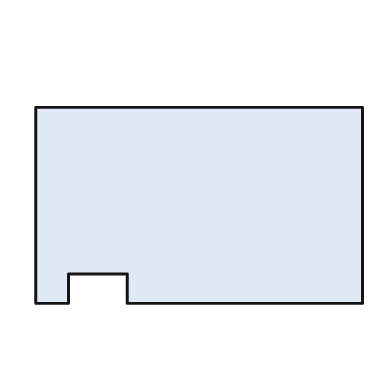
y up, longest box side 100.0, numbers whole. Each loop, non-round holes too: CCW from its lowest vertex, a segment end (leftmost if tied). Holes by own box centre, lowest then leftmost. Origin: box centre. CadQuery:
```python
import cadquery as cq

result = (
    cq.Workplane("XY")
    .moveTo(-50.0, -30.0)
    .lineTo(-40.0, -30.0)
    .lineTo(-40.0, -21.0)
    .lineTo(-22.0, -21.0)
    .lineTo(-22.0, -30.0)
    .lineTo(50.0, -30.0)
    .lineTo(50.0, 30.0)
    .lineTo(-50.0, 30.0)
    .close()
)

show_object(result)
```